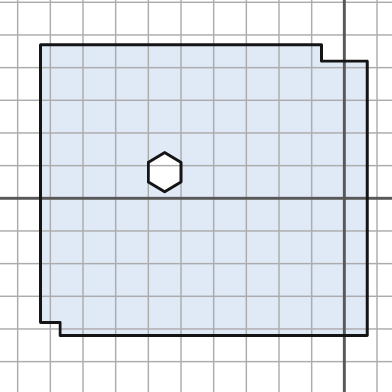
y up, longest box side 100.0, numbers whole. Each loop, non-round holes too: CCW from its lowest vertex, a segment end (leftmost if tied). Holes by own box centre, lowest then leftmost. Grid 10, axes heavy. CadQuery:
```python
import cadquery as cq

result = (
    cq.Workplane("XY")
    .moveTo(-87.0, -42.0)
    .lineTo(7.0, -42.0)
    .lineTo(7.0, 42.0)
    .lineTo(-7.0, 42.0)
    .lineTo(-7.0, 47.0)
    .lineTo(-93.0, 47.0)
    .lineTo(-93.0, -38.0)
    .lineTo(-87.0, -38.0)
    .close()
    .moveTo(-55.0, 2.0)
    .lineTo(-50.0, 5.0)
    .lineTo(-50.0, 11.0)
    .lineTo(-55.0, 14.0)
    .lineTo(-60.0, 11.0)
    .lineTo(-60.0, 5.0)
    .close()
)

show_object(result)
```